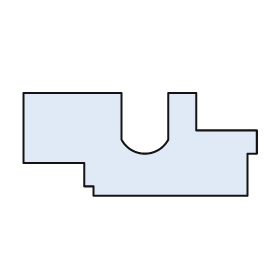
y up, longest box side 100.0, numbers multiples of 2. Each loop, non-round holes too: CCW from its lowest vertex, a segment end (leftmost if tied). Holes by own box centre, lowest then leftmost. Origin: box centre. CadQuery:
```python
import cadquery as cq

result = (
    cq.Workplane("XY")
    .moveTo(-20.0, -22.0)
    .lineTo(46.0, -22.0)
    .lineTo(46.0, -4.0)
    .lineTo(50.0, -4.0)
    .lineTo(50.0, 6.0)
    .lineTo(24.0, 6.0)
    .lineTo(24.0, 22.0)
    .lineTo(12.0, 22.0)
    .lineTo(12.0, 2.0)
    .threePointArc((2.0, -4.0), (-8.0, 2.0))
    .lineTo(-8.0, 22.0)
    .lineTo(-50.0, 22.0)
    .lineTo(-50.0, -8.0)
    .lineTo(-24.0, -8.0)
    .lineTo(-24.0, -18.0)
    .lineTo(-20.0, -18.0)
    .close()
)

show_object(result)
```